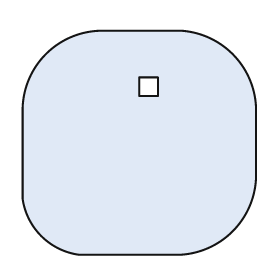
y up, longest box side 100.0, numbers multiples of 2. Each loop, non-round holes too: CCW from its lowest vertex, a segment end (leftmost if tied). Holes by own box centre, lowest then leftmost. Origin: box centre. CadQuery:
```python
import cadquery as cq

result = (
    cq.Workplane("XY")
    .moveTo(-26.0, -48.0)
    .lineTo(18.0, -48.0)
    .threePointArc((40.0, -38.0), (50.0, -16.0))
    .lineTo(50.0, 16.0)
    .threePointArc((40.0, 38.0), (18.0, 48.0))
    .lineTo(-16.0, 48.0)
    .threePointArc((-40.0, 38.0), (-50.0, 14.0))
    .lineTo(-50.0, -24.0)
    .threePointArc((-42.0, -40.0), (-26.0, -48.0))
    .close()
    .moveTo(0.0, 20.0)
    .lineTo(8.0, 20.0)
    .lineTo(8.0, 28.0)
    .lineTo(0.0, 28.0)
    .close()
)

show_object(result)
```